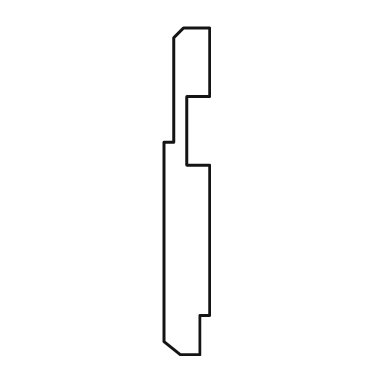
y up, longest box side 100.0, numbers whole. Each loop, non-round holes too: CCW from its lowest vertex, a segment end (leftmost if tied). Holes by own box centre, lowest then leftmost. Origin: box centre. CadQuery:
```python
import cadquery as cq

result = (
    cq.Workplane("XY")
    .moveTo(-2.0, -50.0)
    .lineTo(4.0, -50.0)
    .lineTo(4.0, -38.0)
    .lineTo(7.0, -38.0)
    .lineTo(7.0, 8.0)
    .lineTo(0.0, 8.0)
    .lineTo(0.0, 29.0)
    .lineTo(7.0, 29.0)
    .lineTo(7.0, 50.0)
    .lineTo(-1.0, 50.0)
    .lineTo(-4.0, 47.0)
    .lineTo(-4.0, 15.0)
    .lineTo(-7.0, 15.0)
    .lineTo(-7.0, -46.0)
    .close()
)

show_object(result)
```